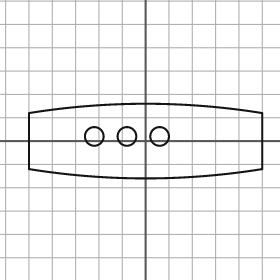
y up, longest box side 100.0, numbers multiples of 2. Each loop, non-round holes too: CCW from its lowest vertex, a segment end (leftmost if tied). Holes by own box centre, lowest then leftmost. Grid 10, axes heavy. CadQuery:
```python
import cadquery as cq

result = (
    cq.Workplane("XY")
    .moveTo(-50.0, -12.0)
    .threePointArc((0.0, -16.0), (50.0, -12.0))
    .lineTo(50.0, 12.0)
    .threePointArc((0.0, 16.0), (-50.0, 12.0))
    .close()
    .moveTo(-22.0, 2.0)
    .circle(4.0)
    .moveTo(-8.0, 2.0)
    .circle(4.0)
    .moveTo(6.0, 2.0)
    .circle(4.0)
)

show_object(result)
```